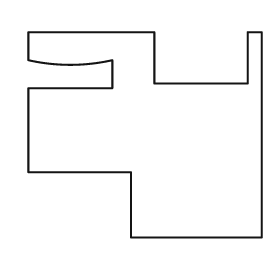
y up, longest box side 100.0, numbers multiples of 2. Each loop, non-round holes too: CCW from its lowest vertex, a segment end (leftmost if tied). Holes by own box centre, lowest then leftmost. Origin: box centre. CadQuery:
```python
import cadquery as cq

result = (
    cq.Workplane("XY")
    .moveTo(-6.0, -44.0)
    .lineTo(50.0, -44.0)
    .lineTo(50.0, 44.0)
    .lineTo(44.0, 44.0)
    .lineTo(44.0, 22.0)
    .lineTo(4.0, 22.0)
    .lineTo(4.0, 44.0)
    .lineTo(-50.0, 44.0)
    .lineTo(-50.0, 32.0)
    .threePointArc((-32.0, 30.0), (-14.0, 32.0))
    .lineTo(-14.0, 20.0)
    .lineTo(-50.0, 20.0)
    .lineTo(-50.0, -16.0)
    .lineTo(-6.0, -16.0)
    .close()
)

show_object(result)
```